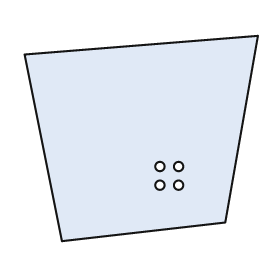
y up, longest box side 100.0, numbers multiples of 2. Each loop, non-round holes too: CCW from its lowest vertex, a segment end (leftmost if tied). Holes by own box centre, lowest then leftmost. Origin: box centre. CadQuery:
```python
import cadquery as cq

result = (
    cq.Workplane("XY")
    .moveTo(-34.0, -44.0)
    .lineTo(36.0, -36.0)
    .lineTo(50.0, 44.0)
    .lineTo(-50.0, 36.0)
    .close()
    .moveTo(8.0, -20.0)
    .circle(2.0)
    .moveTo(16.0, -20.0)
    .circle(2.0)
    .moveTo(8.0, -12.0)
    .circle(2.0)
    .moveTo(16.0, -12.0)
    .circle(2.0)
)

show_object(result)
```